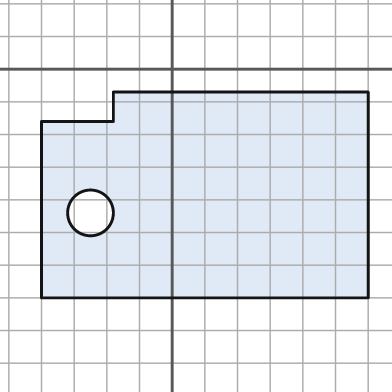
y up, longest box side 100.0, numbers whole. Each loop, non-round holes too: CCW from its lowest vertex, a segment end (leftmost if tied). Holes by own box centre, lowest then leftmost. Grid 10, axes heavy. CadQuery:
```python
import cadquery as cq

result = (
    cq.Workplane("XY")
    .moveTo(-40.0, -70.0)
    .lineTo(60.0, -70.0)
    .lineTo(60.0, -7.0)
    .lineTo(-18.0, -7.0)
    .lineTo(-18.0, -16.0)
    .lineTo(-40.0, -16.0)
    .close()
    .moveTo(-25.0, -44.0)
    .circle(7.0)
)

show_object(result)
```